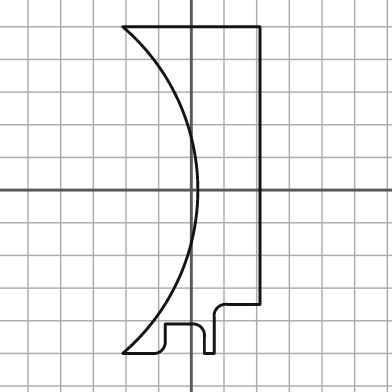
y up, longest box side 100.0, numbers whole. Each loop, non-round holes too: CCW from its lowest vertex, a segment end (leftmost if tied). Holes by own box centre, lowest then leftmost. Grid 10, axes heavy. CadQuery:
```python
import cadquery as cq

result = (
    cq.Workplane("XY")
    .moveTo(-21.0, -50.0)
    .lineTo(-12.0, -50.0)
    .threePointArc((-9.0, -49.0), (-8.0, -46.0))
    .lineTo(-8.0, -41.0)
    .lineTo(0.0, -41.0)
    .threePointArc((3.0, -42.0), (4.0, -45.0))
    .lineTo(4.0, -50.0)
    .lineTo(7.0, -50.0)
    .lineTo(7.0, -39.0)
    .threePointArc((8.0, -36.0), (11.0, -35.0))
    .lineTo(21.0, -35.0)
    .lineTo(21.0, 50.0)
    .lineTo(-21.0, 50.0)
    .threePointArc((2.0, 0.0), (-21.0, -50.0))
    .close()
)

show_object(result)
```